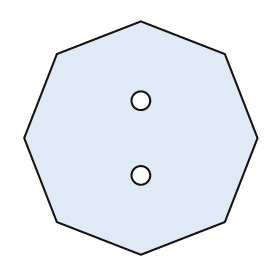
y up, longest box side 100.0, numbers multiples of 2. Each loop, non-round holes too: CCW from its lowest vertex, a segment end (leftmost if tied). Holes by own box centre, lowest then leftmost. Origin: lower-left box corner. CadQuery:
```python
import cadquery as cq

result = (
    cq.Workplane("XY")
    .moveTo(50.0, 0.0)
    .lineTo(86.0, 14.0)
    .lineTo(100.0, 50.0)
    .lineTo(86.0, 86.0)
    .lineTo(50.0, 100.0)
    .lineTo(14.0, 86.0)
    .lineTo(0.0, 50.0)
    .lineTo(14.0, 14.0)
    .close()
    .moveTo(50.0, 34.0)
    .circle(4.0)
    .moveTo(50.0, 66.0)
    .circle(4.0)
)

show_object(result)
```